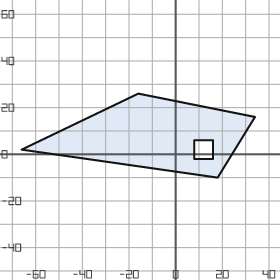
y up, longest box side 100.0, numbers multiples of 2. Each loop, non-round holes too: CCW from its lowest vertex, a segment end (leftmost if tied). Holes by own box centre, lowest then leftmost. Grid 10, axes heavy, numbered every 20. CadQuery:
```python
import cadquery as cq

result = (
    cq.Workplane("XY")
    .moveTo(18.0, -10.0)
    .lineTo(34.0, 16.0)
    .lineTo(-16.0, 26.0)
    .lineTo(-66.0, 2.0)
    .close()
    .moveTo(8.0, -2.0)
    .lineTo(16.0, -2.0)
    .lineTo(16.0, 6.0)
    .lineTo(8.0, 6.0)
    .close()
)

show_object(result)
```